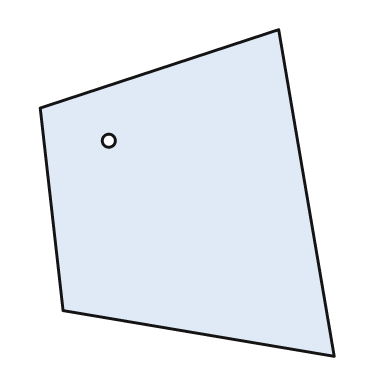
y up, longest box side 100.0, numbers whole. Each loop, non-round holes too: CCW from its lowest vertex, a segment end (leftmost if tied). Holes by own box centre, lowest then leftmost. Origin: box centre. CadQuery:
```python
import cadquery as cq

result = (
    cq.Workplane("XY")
    .moveTo(45.0, -50.0)
    .lineTo(28.0, 50.0)
    .lineTo(-45.0, 26.0)
    .lineTo(-38.0, -36.0)
    .close()
    .moveTo(-24.0, 16.0)
    .circle(2.0)
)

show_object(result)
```